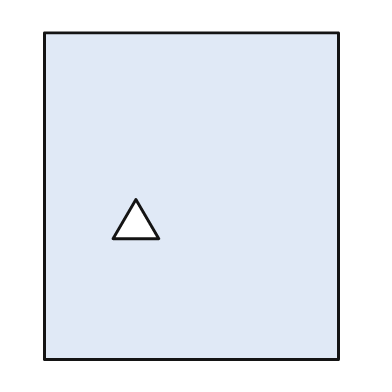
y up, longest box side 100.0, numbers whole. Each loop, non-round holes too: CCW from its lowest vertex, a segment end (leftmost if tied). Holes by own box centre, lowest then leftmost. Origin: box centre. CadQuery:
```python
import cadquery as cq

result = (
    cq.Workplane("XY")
    .moveTo(-45.0, -50.0)
    .lineTo(45.0, -50.0)
    .lineTo(45.0, 50.0)
    .lineTo(-45.0, 50.0)
    .close()
    .moveTo(-24.0, -13.0)
    .lineTo(-10.0, -13.0)
    .lineTo(-17.0, -1.0)
    .close()
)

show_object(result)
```